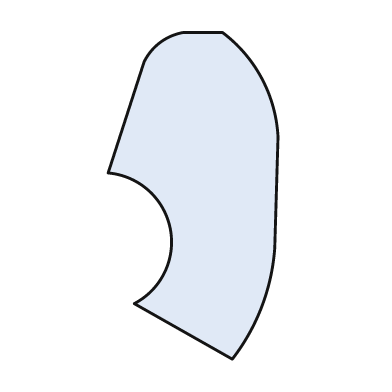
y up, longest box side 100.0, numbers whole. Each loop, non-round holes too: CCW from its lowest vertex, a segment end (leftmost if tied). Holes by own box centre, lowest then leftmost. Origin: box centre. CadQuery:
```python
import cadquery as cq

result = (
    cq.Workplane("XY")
    .moveTo(12.0, -50.0)
    .threePointArc((21.0, -34.0), (25.0, -16.0))
    .lineTo(26.0, 18.0)
    .threePointArc((21.0, 36.0), (9.0, 50.0))
    .lineTo(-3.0, 50.0)
    .threePointArc((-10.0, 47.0), (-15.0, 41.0))
    .lineTo(-26.0, 7.0)
    .threePointArc((-7.0, -10.0), (-18.0, -33.0))
    .close()
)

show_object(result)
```